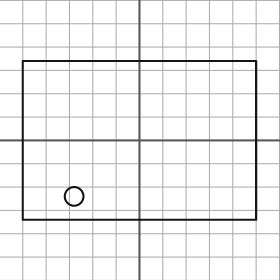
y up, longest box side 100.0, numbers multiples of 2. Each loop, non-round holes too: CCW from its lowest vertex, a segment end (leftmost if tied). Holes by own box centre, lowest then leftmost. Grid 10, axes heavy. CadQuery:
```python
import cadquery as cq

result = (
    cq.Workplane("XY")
    .moveTo(-50.0, -34.0)
    .lineTo(50.0, -34.0)
    .lineTo(50.0, 34.0)
    .lineTo(-50.0, 34.0)
    .close()
    .moveTo(-28.0, -24.0)
    .circle(4.0)
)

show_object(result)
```